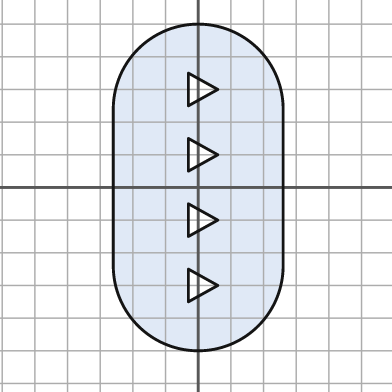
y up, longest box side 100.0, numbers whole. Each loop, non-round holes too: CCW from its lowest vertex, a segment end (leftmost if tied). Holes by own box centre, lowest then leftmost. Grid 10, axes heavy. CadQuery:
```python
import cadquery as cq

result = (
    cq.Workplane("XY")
    .moveTo(-26.0, -24.0)
    .threePointArc((0.0, -50.0), (26.0, -24.0))
    .lineTo(26.0, 24.0)
    .threePointArc((0.0, 50.0), (-26.0, 24.0))
    .close()
    .moveTo(-3.0, -35.0)
    .lineTo(6.0, -30.0)
    .lineTo(-3.0, -25.0)
    .close()
    .moveTo(-3.0, -15.0)
    .lineTo(6.0, -10.0)
    .lineTo(-3.0, -5.0)
    .close()
    .moveTo(-3.0, 5.0)
    .lineTo(6.0, 10.0)
    .lineTo(-3.0, 15.0)
    .close()
    .moveTo(-3.0, 25.0)
    .lineTo(6.0, 30.0)
    .lineTo(-3.0, 35.0)
    .close()
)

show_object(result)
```